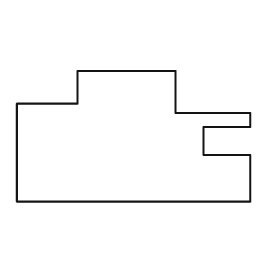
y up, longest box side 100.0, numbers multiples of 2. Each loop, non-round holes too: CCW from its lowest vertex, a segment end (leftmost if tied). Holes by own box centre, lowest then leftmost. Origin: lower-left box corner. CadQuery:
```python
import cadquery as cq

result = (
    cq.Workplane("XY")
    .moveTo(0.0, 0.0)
    .lineTo(100.0, 0.0)
    .lineTo(100.0, 20.0)
    .lineTo(80.0, 20.0)
    .lineTo(80.0, 32.0)
    .lineTo(100.0, 32.0)
    .lineTo(100.0, 38.0)
    .lineTo(68.0, 38.0)
    .lineTo(68.0, 56.0)
    .lineTo(26.0, 56.0)
    .lineTo(26.0, 42.0)
    .lineTo(0.0, 42.0)
    .close()
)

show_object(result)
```